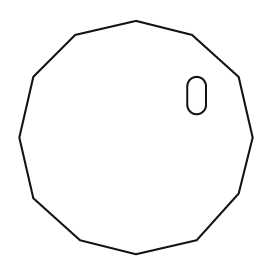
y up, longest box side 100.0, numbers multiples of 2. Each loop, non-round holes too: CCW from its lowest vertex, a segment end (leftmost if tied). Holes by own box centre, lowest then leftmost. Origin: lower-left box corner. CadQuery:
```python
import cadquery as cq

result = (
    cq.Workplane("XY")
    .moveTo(50.0, 0.0)
    .lineTo(76.0, 6.0)
    .lineTo(94.0, 26.0)
    .lineTo(100.0, 50.0)
    .lineTo(94.0, 76.0)
    .lineTo(74.0, 94.0)
    .lineTo(50.0, 100.0)
    .lineTo(24.0, 94.0)
    .lineTo(6.0, 76.0)
    .lineTo(0.0, 50.0)
    .lineTo(6.0, 24.0)
    .lineTo(26.0, 6.0)
    .close()
    .moveTo(72.0, 64.0)
    .threePointArc((76.0, 60.0), (80.0, 64.0))
    .lineTo(80.0, 72.0)
    .threePointArc((76.0, 76.0), (72.0, 72.0))
    .close()
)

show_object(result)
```